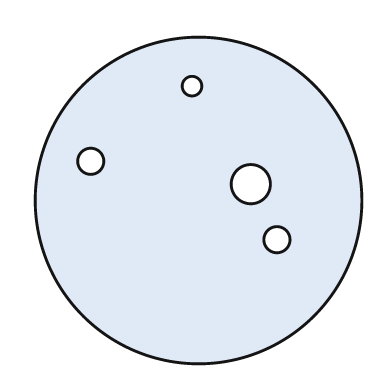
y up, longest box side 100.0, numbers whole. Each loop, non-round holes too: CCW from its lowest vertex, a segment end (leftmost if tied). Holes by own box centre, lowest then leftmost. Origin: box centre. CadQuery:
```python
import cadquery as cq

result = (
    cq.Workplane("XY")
    .moveTo(0.0, 0.0)
    .circle(50.0)
    .moveTo(24.0, -12.0)
    .circle(4.0)
    .moveTo(16.0, 5.0)
    .circle(6.0)
    .moveTo(-33.0, 12.0)
    .circle(4.0)
    .moveTo(-2.0, 35.0)
    .circle(3.0)
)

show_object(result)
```